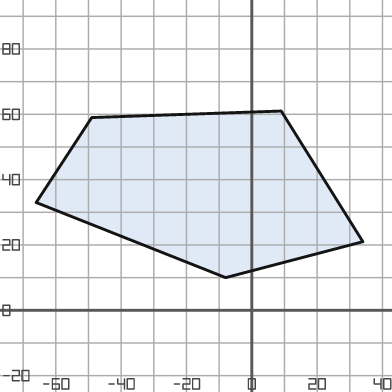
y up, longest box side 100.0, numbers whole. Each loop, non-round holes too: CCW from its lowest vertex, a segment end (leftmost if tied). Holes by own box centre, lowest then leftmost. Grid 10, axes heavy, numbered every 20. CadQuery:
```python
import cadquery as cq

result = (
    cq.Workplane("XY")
    .moveTo(-8.0, 10.0)
    .lineTo(34.0, 21.0)
    .lineTo(9.0, 61.0)
    .lineTo(-49.0, 59.0)
    .lineTo(-66.0, 33.0)
    .close()
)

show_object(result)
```